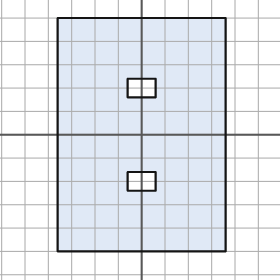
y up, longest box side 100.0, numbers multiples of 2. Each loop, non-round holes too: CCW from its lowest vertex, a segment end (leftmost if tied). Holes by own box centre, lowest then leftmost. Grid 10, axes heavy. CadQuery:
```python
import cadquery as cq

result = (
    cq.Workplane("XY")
    .moveTo(-36.0, -50.0)
    .lineTo(36.0, -50.0)
    .lineTo(36.0, 50.0)
    .lineTo(-36.0, 50.0)
    .close()
    .moveTo(-6.0, -24.0)
    .lineTo(6.0, -24.0)
    .lineTo(6.0, -16.0)
    .lineTo(-6.0, -16.0)
    .close()
    .moveTo(-6.0, 16.0)
    .lineTo(6.0, 16.0)
    .lineTo(6.0, 24.0)
    .lineTo(-6.0, 24.0)
    .close()
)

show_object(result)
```